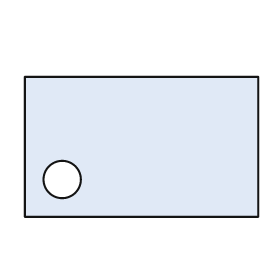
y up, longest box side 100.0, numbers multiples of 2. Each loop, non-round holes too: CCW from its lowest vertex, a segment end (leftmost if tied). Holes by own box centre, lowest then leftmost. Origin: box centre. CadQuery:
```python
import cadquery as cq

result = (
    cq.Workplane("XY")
    .moveTo(-50.0, -30.0)
    .lineTo(50.0, -30.0)
    .lineTo(50.0, 30.0)
    .lineTo(-50.0, 30.0)
    .close()
    .moveTo(-34.0, -14.0)
    .circle(8.0)
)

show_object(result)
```